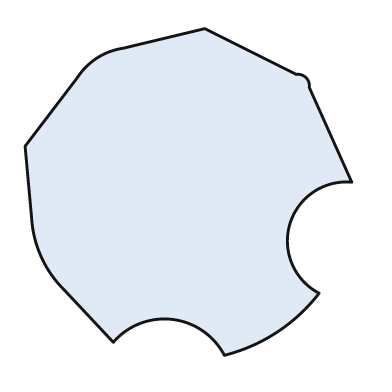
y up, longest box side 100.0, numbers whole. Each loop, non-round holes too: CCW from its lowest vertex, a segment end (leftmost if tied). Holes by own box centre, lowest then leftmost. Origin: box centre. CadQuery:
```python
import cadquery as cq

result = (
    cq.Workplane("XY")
    .moveTo(11.0, -50.0)
    .threePointArc((27.0, -43.0), (40.0, -31.0))
    .threePointArc((31.0, -10.0), (50.0, 3.0))
    .lineTo(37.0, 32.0)
    .threePointArc((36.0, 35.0), (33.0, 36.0))
    .lineTo(5.0, 50.0)
    .lineTo(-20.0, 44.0)
    .threePointArc((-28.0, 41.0), (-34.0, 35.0))
    .lineTo(-50.0, 14.0)
    .lineTo(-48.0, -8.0)
    .threePointArc((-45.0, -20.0), (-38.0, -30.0))
    .lineTo(-23.0, -46.0)
    .threePointArc((-5.0, -39.0), (11.0, -50.0))
    .close()
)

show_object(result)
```